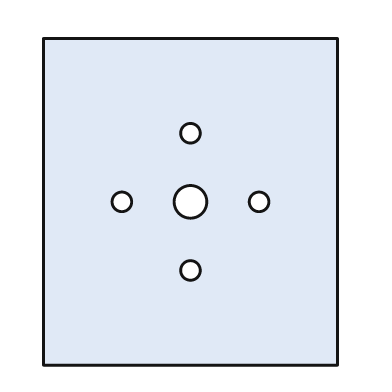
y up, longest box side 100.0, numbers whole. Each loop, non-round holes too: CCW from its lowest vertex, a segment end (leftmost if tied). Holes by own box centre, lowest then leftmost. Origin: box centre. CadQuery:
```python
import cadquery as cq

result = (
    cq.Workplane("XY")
    .moveTo(-45.0, -50.0)
    .lineTo(45.0, -50.0)
    .lineTo(45.0, 50.0)
    .lineTo(-45.0, 50.0)
    .close()
    .moveTo(0.0, -21.0)
    .circle(3.0)
    .moveTo(-21.0, 0.0)
    .circle(3.0)
    .moveTo(0.0, 0.0)
    .circle(5.0)
    .moveTo(21.0, 0.0)
    .circle(3.0)
    .moveTo(0.0, 21.0)
    .circle(3.0)
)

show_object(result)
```